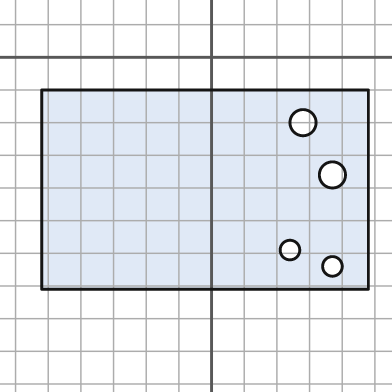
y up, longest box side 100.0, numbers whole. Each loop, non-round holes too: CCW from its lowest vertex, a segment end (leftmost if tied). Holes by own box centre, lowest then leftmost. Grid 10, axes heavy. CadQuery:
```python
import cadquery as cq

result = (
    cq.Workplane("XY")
    .moveTo(-52.0, -71.0)
    .lineTo(48.0, -71.0)
    .lineTo(48.0, -10.0)
    .lineTo(-52.0, -10.0)
    .close()
    .moveTo(37.0, -64.0)
    .circle(3.0)
    .moveTo(24.0, -59.0)
    .circle(3.0)
    .moveTo(37.0, -36.0)
    .circle(4.0)
    .moveTo(28.0, -20.0)
    .circle(4.0)
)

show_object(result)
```